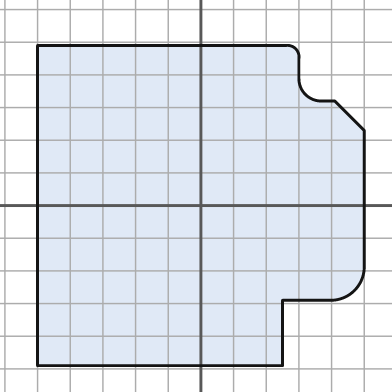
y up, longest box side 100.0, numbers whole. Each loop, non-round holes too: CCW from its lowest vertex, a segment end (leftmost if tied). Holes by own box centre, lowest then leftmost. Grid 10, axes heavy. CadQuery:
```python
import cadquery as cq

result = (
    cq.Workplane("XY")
    .moveTo(-50.0, -49.0)
    .lineTo(25.0, -49.0)
    .lineTo(25.0, -29.0)
    .lineTo(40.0, -29.0)
    .threePointArc((47.0, -26.0), (50.0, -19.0))
    .lineTo(50.0, 23.0)
    .lineTo(41.0, 32.0)
    .lineTo(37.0, 32.0)
    .threePointArc((32.0, 34.0), (30.0, 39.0))
    .lineTo(30.0, 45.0)
    .threePointArc((29.0, 48.0), (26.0, 49.0))
    .lineTo(-50.0, 49.0)
    .close()
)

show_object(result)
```